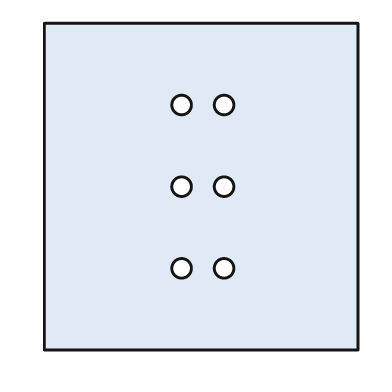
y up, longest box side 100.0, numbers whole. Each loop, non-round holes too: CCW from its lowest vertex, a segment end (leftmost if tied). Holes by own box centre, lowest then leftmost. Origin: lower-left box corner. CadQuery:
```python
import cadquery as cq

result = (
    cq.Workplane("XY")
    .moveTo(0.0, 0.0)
    .lineTo(96.0, 0.0)
    .lineTo(96.0, 100.0)
    .lineTo(0.0, 100.0)
    .close()
    .moveTo(42.0, 25.0)
    .circle(3.0)
    .moveTo(55.0, 25.0)
    .circle(3.0)
    .moveTo(42.0, 50.0)
    .circle(3.0)
    .moveTo(55.0, 50.0)
    .circle(3.0)
    .moveTo(42.0, 75.0)
    .circle(3.0)
    .moveTo(55.0, 75.0)
    .circle(3.0)
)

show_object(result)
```